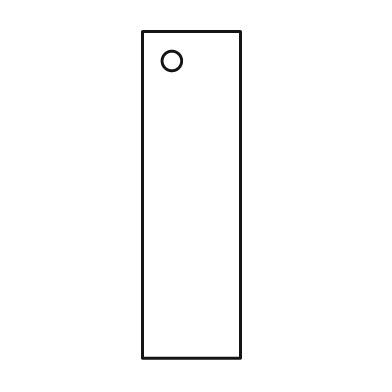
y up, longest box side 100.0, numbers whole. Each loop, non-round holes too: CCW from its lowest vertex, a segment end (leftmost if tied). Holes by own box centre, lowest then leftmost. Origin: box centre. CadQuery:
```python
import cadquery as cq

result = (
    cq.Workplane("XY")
    .moveTo(-15.0, -50.0)
    .lineTo(15.0, -50.0)
    .lineTo(15.0, 50.0)
    .lineTo(-15.0, 50.0)
    .close()
    .moveTo(-6.0, 41.0)
    .circle(3.0)
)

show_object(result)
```